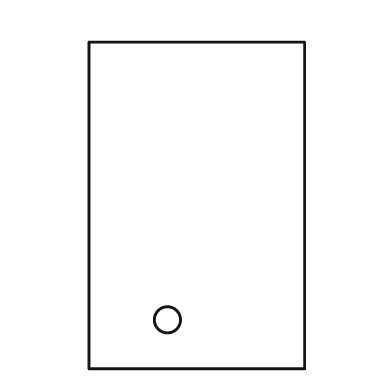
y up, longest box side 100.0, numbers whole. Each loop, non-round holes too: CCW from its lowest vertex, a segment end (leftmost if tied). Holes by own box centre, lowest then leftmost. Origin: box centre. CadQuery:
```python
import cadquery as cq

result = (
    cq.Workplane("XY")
    .moveTo(-33.0, -50.0)
    .lineTo(33.0, -50.0)
    .lineTo(33.0, 50.0)
    .lineTo(-33.0, 50.0)
    .close()
    .moveTo(-9.0, -35.0)
    .circle(4.0)
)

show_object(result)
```